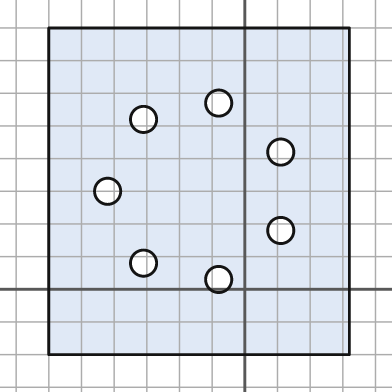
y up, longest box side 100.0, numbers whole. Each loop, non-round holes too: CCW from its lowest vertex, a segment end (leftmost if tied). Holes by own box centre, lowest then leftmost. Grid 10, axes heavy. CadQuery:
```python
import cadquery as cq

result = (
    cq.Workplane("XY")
    .moveTo(-60.0, -20.0)
    .lineTo(32.0, -20.0)
    .lineTo(32.0, 80.0)
    .lineTo(-60.0, 80.0)
    .close()
    .moveTo(-8.0, 3.0)
    .circle(4.0)
    .moveTo(-31.0, 8.0)
    .circle(4.0)
    .moveTo(11.0, 18.0)
    .circle(4.0)
    .moveTo(-42.0, 30.0)
    .circle(4.0)
    .moveTo(11.0, 42.0)
    .circle(4.0)
    .moveTo(-31.0, 52.0)
    .circle(4.0)
    .moveTo(-8.0, 57.0)
    .circle(4.0)
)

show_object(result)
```